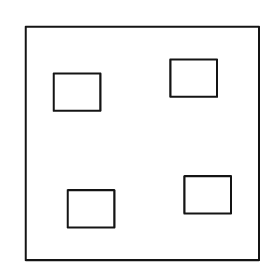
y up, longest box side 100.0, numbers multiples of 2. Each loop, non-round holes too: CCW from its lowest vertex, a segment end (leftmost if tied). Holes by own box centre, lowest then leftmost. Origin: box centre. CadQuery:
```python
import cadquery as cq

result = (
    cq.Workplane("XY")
    .moveTo(-50.0, -50.0)
    .lineTo(50.0, -50.0)
    .lineTo(50.0, 50.0)
    .lineTo(-50.0, 50.0)
    .close()
    .moveTo(-32.0, -36.0)
    .lineTo(-12.0, -36.0)
    .lineTo(-12.0, -20.0)
    .lineTo(-32.0, -20.0)
    .close()
    .moveTo(18.0, -30.0)
    .lineTo(38.0, -30.0)
    .lineTo(38.0, -14.0)
    .lineTo(18.0, -14.0)
    .close()
    .moveTo(-38.0, 14.0)
    .lineTo(-18.0, 14.0)
    .lineTo(-18.0, 30.0)
    .lineTo(-38.0, 30.0)
    .close()
    .moveTo(12.0, 20.0)
    .lineTo(32.0, 20.0)
    .lineTo(32.0, 36.0)
    .lineTo(12.0, 36.0)
    .close()
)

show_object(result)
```